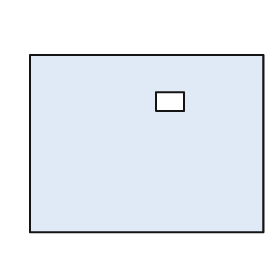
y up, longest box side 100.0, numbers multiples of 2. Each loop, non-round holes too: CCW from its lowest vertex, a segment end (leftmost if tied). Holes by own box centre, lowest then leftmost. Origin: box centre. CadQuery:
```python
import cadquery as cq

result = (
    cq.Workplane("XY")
    .moveTo(-50.0, -38.0)
    .lineTo(50.0, -38.0)
    .lineTo(50.0, 38.0)
    .lineTo(-50.0, 38.0)
    .close()
    .moveTo(4.0, 14.0)
    .lineTo(16.0, 14.0)
    .lineTo(16.0, 22.0)
    .lineTo(4.0, 22.0)
    .close()
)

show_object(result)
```